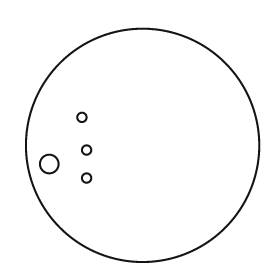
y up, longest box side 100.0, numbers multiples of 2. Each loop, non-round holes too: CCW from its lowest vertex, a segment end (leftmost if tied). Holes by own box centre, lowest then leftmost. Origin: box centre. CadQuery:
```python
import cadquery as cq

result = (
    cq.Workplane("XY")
    .moveTo(0.0, 0.0)
    .circle(50.0)
    .moveTo(-24.0, -14.0)
    .circle(2.0)
    .moveTo(-40.0, -8.0)
    .circle(4.0)
    .moveTo(-24.0, -2.0)
    .circle(2.0)
    .moveTo(-26.0, 12.0)
    .circle(2.0)
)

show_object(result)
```